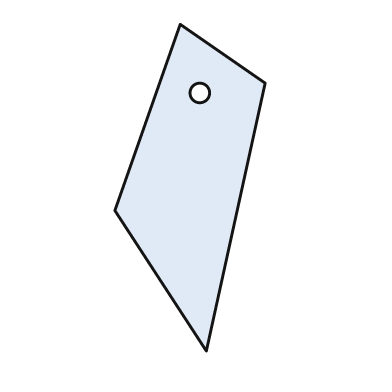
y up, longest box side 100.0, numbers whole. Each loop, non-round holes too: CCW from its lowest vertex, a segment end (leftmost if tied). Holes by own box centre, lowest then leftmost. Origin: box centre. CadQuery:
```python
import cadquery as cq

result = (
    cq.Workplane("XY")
    .moveTo(5.0, -50.0)
    .lineTo(23.0, 32.0)
    .lineTo(-3.0, 50.0)
    .lineTo(-23.0, -7.0)
    .close()
    .moveTo(3.0, 29.0)
    .circle(3.0)
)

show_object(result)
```